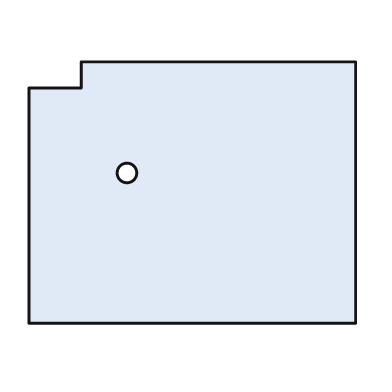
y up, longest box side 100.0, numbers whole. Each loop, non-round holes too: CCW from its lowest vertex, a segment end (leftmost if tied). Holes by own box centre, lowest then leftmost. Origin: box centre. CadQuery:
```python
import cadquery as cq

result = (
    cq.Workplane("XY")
    .moveTo(-50.0, -40.0)
    .lineTo(50.0, -40.0)
    .lineTo(50.0, 40.0)
    .lineTo(-34.0, 40.0)
    .lineTo(-34.0, 32.0)
    .lineTo(-50.0, 32.0)
    .close()
    .moveTo(-20.0, 6.0)
    .circle(3.0)
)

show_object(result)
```